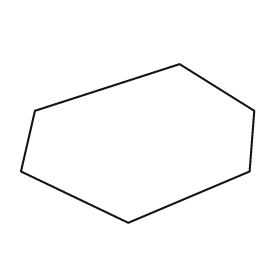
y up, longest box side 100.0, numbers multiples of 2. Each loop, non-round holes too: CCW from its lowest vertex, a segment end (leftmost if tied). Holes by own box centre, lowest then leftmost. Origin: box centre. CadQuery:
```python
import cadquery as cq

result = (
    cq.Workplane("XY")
    .moveTo(-4.0, -34.0)
    .lineTo(48.0, -12.0)
    .lineTo(50.0, 14.0)
    .lineTo(18.0, 34.0)
    .lineTo(-44.0, 14.0)
    .lineTo(-50.0, -12.0)
    .close()
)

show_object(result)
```